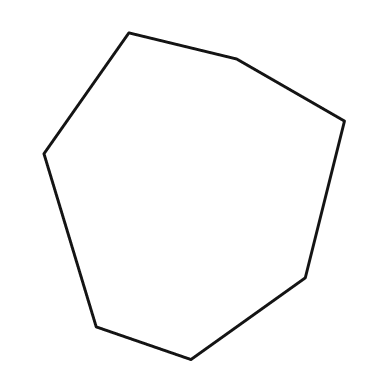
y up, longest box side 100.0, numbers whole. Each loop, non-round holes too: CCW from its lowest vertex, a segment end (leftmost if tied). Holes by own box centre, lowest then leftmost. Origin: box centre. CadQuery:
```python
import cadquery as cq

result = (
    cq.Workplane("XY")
    .moveTo(-1.0, -50.0)
    .lineTo(34.0, -25.0)
    .lineTo(46.0, 23.0)
    .lineTo(13.0, 42.0)
    .lineTo(-20.0, 50.0)
    .lineTo(-46.0, 13.0)
    .lineTo(-30.0, -40.0)
    .close()
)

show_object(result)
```